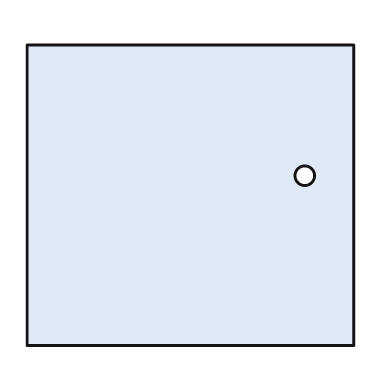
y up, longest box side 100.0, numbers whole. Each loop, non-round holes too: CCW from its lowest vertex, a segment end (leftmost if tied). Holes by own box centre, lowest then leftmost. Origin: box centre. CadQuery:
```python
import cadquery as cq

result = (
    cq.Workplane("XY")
    .moveTo(-50.0, -46.0)
    .lineTo(50.0, -46.0)
    .lineTo(50.0, 46.0)
    .lineTo(-50.0, 46.0)
    .close()
    .moveTo(35.0, 6.0)
    .circle(3.0)
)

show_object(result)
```